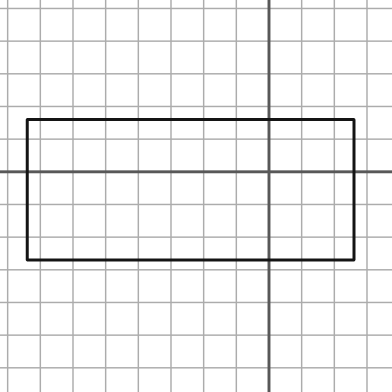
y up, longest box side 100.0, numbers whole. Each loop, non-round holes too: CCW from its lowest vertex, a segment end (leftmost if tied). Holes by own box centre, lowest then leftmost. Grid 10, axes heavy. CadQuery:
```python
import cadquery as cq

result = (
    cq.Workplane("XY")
    .moveTo(-74.0, -27.0)
    .lineTo(26.0, -27.0)
    .lineTo(26.0, 16.0)
    .lineTo(-74.0, 16.0)
    .close()
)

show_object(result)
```